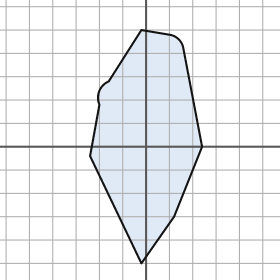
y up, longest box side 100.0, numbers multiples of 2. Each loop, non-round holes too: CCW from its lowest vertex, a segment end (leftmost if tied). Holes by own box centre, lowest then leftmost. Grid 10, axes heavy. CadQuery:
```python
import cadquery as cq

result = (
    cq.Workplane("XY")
    .moveTo(-2.0, -50.0)
    .lineTo(12.0, -30.0)
    .lineTo(24.0, 0.0)
    .lineTo(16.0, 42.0)
    .threePointArc((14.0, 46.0), (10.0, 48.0))
    .lineTo(-2.0, 50.0)
    .lineTo(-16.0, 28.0)
    .threePointArc((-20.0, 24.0), (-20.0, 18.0))
    .lineTo(-24.0, -4.0)
    .close()
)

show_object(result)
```